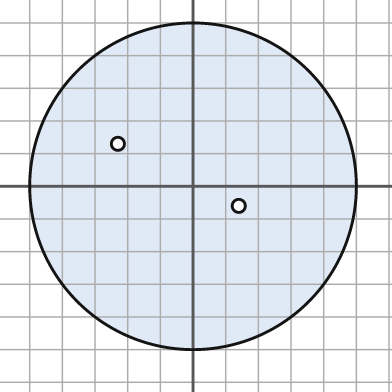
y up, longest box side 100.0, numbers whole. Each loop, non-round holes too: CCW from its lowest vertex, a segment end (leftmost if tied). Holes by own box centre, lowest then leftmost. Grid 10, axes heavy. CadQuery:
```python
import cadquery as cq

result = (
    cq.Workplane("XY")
    .moveTo(0.0, 0.0)
    .circle(50.0)
    .moveTo(14.0, -6.0)
    .circle(2.0)
    .moveTo(-23.0, 13.0)
    .circle(2.0)
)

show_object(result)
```